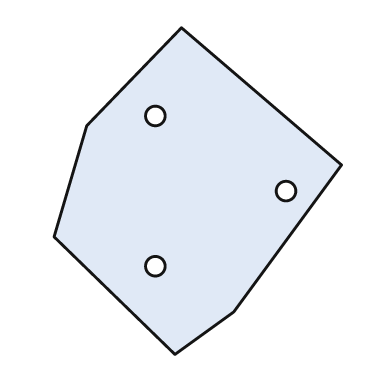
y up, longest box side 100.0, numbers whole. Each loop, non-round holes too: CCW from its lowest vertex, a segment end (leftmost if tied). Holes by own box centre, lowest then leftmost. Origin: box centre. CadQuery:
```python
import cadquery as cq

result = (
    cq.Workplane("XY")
    .moveTo(-7.0, -50.0)
    .lineTo(11.0, -37.0)
    .lineTo(44.0, 8.0)
    .lineTo(-5.0, 50.0)
    .lineTo(-34.0, 20.0)
    .lineTo(-44.0, -14.0)
    .close()
    .moveTo(-13.0, -23.0)
    .circle(3.0)
    .moveTo(27.0, 0.0)
    .circle(3.0)
    .moveTo(-13.0, 23.0)
    .circle(3.0)
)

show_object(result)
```